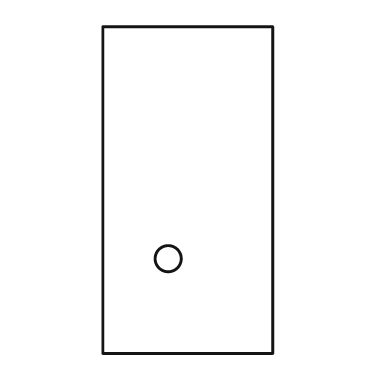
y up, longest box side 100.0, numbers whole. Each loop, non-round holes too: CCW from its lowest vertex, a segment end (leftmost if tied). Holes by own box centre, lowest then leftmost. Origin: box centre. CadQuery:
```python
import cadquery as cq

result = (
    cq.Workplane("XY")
    .moveTo(-26.0, -50.0)
    .lineTo(26.0, -50.0)
    .lineTo(26.0, 50.0)
    .lineTo(-26.0, 50.0)
    .close()
    .moveTo(-6.0, -21.0)
    .circle(4.0)
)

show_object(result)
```